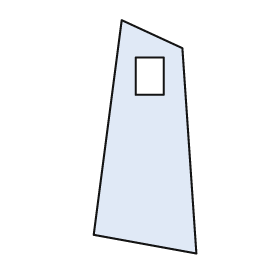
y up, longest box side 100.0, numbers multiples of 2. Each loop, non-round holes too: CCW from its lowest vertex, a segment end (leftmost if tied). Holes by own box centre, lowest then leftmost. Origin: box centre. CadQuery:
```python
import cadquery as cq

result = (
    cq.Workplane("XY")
    .moveTo(22.0, -50.0)
    .lineTo(16.0, 38.0)
    .lineTo(-10.0, 50.0)
    .lineTo(-22.0, -42.0)
    .close()
    .moveTo(-4.0, 18.0)
    .lineTo(8.0, 18.0)
    .lineTo(8.0, 34.0)
    .lineTo(-4.0, 34.0)
    .close()
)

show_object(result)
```